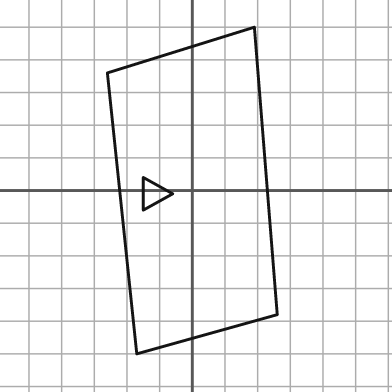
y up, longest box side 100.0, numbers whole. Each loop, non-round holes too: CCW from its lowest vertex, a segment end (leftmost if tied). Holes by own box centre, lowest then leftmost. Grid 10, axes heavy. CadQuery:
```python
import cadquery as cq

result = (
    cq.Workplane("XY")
    .moveTo(-17.0, -50.0)
    .lineTo(26.0, -38.0)
    .lineTo(19.0, 50.0)
    .lineTo(-26.0, 36.0)
    .close()
    .moveTo(-15.0, -6.0)
    .lineTo(-6.0, -1.0)
    .lineTo(-15.0, 4.0)
    .close()
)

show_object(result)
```